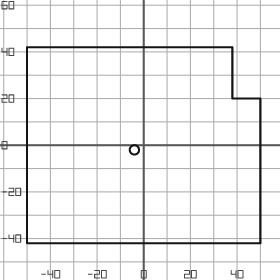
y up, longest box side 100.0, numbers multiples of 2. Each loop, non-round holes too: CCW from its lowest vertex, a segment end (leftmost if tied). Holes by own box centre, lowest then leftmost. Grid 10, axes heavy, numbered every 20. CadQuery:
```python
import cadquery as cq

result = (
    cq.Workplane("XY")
    .moveTo(-50.0, -42.0)
    .lineTo(50.0, -42.0)
    .lineTo(50.0, 20.0)
    .lineTo(38.0, 20.0)
    .lineTo(38.0, 42.0)
    .lineTo(-50.0, 42.0)
    .close()
    .moveTo(-4.0, -2.0)
    .circle(2.0)
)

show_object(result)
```